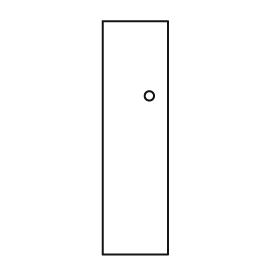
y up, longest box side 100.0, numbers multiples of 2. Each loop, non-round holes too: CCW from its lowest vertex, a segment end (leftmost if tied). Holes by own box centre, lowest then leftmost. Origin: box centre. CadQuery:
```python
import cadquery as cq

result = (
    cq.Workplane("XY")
    .moveTo(-14.0, -50.0)
    .lineTo(14.0, -50.0)
    .lineTo(14.0, 50.0)
    .lineTo(-14.0, 50.0)
    .close()
    .moveTo(6.0, 18.0)
    .circle(2.0)
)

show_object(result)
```